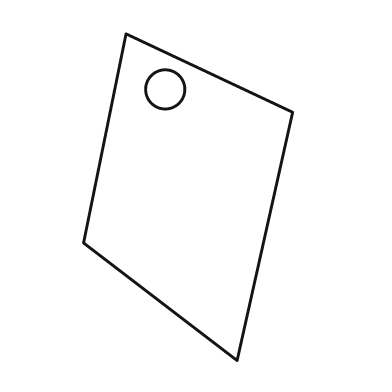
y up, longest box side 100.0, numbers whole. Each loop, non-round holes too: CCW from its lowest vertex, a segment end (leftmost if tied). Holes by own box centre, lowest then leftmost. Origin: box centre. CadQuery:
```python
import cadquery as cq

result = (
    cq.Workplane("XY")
    .moveTo(15.0, -50.0)
    .lineTo(32.0, 26.0)
    .lineTo(-19.0, 50.0)
    .lineTo(-32.0, -14.0)
    .close()
    .moveTo(-7.0, 33.0)
    .circle(6.0)
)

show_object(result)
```